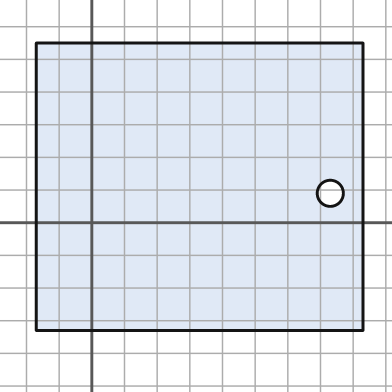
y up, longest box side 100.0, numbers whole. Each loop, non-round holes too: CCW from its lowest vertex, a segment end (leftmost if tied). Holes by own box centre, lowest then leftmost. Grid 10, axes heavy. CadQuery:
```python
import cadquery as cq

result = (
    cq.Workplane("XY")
    .moveTo(-17.0, -33.0)
    .lineTo(83.0, -33.0)
    .lineTo(83.0, 55.0)
    .lineTo(-17.0, 55.0)
    .close()
    .moveTo(73.0, 9.0)
    .circle(4.0)
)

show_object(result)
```